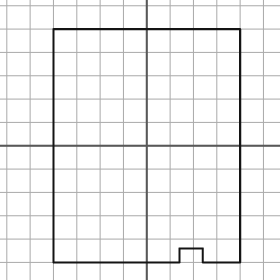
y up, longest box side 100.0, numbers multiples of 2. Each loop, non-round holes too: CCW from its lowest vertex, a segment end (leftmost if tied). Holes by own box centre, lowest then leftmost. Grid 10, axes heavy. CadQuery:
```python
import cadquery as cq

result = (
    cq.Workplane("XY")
    .moveTo(-40.0, -50.0)
    .lineTo(14.0, -50.0)
    .lineTo(14.0, -44.0)
    .lineTo(24.0, -44.0)
    .lineTo(24.0, -50.0)
    .lineTo(40.0, -50.0)
    .lineTo(40.0, 50.0)
    .lineTo(-40.0, 50.0)
    .close()
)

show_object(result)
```